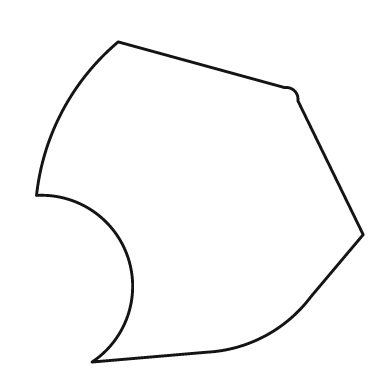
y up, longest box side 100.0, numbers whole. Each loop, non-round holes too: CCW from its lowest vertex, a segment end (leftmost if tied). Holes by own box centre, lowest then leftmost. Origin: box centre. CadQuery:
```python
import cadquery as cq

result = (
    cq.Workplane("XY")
    .moveTo(-33.0, -49.0)
    .lineTo(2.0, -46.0)
    .threePointArc((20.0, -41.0), (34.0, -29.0))
    .lineTo(50.0, -10.0)
    .lineTo(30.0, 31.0)
    .threePointArc((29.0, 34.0), (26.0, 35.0))
    .lineTo(-25.0, 49.0)
    .threePointArc((-42.0, 28.0), (-50.0, 2.0))
    .threePointArc((-22.0, -17.0), (-33.0, -49.0))
    .close()
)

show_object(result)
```